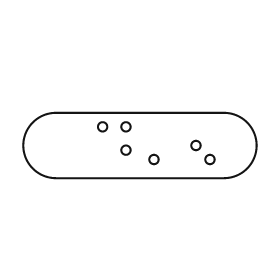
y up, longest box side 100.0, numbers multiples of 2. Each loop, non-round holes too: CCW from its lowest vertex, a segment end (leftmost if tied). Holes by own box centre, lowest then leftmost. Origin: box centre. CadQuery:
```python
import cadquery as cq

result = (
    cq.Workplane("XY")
    .moveTo(-36.0, -14.0)
    .lineTo(36.0, -14.0)
    .threePointArc((50.0, 0.0), (36.0, 14.0))
    .lineTo(-36.0, 14.0)
    .threePointArc((-50.0, 0.0), (-36.0, -14.0))
    .close()
    .moveTo(6.0, -6.0)
    .circle(2.0)
    .moveTo(30.0, -6.0)
    .circle(2.0)
    .moveTo(-6.0, -2.0)
    .circle(2.0)
    .moveTo(24.0, 0.0)
    .circle(2.0)
    .moveTo(-16.0, 8.0)
    .circle(2.0)
    .moveTo(-6.0, 8.0)
    .circle(2.0)
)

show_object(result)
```